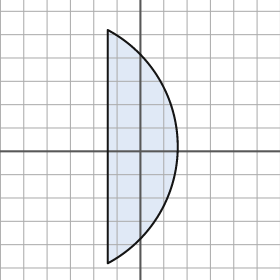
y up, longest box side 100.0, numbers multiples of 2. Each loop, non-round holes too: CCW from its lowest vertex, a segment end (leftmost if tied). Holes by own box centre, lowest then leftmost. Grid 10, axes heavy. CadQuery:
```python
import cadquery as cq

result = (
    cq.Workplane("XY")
    .moveTo(-14.0, -48.0)
    .threePointArc((16.0, 2.0), (-14.0, 52.0))
    .close()
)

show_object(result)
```